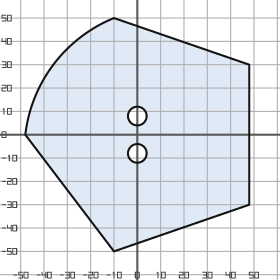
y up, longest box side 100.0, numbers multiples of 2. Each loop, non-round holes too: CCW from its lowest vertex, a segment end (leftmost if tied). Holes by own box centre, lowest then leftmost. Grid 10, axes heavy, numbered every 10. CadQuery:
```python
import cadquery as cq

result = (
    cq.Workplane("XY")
    .moveTo(-10.0, -50.0)
    .lineTo(48.0, -30.0)
    .lineTo(48.0, 30.0)
    .lineTo(-10.0, 50.0)
    .threePointArc((-36.0, 30.0), (-48.0, 0.0))
    .close()
    .moveTo(0.0, -8.0)
    .circle(4.0)
    .moveTo(0.0, 8.0)
    .circle(4.0)
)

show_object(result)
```